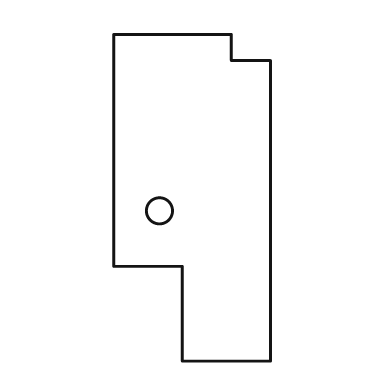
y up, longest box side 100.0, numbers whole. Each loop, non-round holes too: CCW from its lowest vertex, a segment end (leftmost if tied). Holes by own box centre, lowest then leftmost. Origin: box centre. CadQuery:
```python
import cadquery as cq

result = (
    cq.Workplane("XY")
    .moveTo(-3.0, -50.0)
    .lineTo(24.0, -50.0)
    .lineTo(24.0, 42.0)
    .lineTo(12.0, 42.0)
    .lineTo(12.0, 50.0)
    .lineTo(-24.0, 50.0)
    .lineTo(-24.0, -21.0)
    .lineTo(-3.0, -21.0)
    .close()
    .moveTo(-10.0, -4.0)
    .circle(4.0)
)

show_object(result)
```